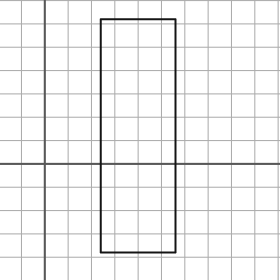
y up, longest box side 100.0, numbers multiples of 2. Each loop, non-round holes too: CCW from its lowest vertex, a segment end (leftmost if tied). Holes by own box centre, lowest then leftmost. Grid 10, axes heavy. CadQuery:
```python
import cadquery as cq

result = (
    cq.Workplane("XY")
    .moveTo(24.0, -38.0)
    .lineTo(56.0, -38.0)
    .lineTo(56.0, 62.0)
    .lineTo(24.0, 62.0)
    .close()
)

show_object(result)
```